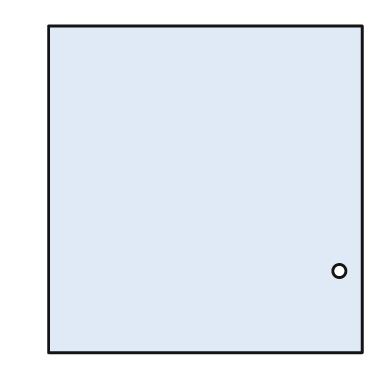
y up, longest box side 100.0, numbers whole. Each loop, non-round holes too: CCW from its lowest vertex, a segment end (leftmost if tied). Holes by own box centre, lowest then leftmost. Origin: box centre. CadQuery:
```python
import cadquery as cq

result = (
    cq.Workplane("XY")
    .moveTo(-48.0, -50.0)
    .lineTo(48.0, -50.0)
    .lineTo(48.0, 50.0)
    .lineTo(-48.0, 50.0)
    .close()
    .moveTo(41.0, -25.0)
    .circle(2.0)
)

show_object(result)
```